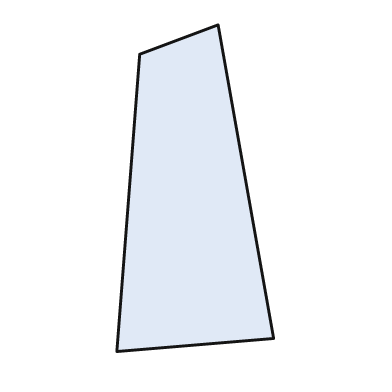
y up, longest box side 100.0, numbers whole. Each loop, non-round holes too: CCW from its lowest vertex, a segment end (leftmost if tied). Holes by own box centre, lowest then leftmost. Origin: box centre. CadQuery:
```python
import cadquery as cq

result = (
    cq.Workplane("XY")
    .moveTo(-24.0, -50.0)
    .lineTo(24.0, -46.0)
    .lineTo(7.0, 50.0)
    .lineTo(-17.0, 41.0)
    .close()
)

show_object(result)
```